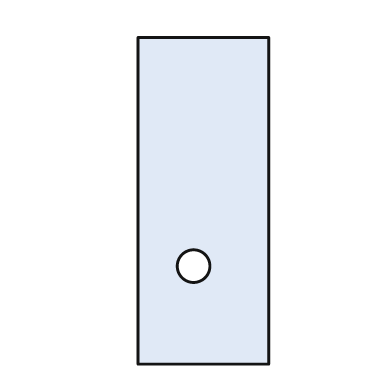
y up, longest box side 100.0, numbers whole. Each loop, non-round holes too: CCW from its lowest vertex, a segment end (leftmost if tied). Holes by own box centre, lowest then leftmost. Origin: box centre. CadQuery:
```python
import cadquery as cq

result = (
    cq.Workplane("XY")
    .moveTo(-20.0, -50.0)
    .lineTo(20.0, -50.0)
    .lineTo(20.0, 50.0)
    .lineTo(-20.0, 50.0)
    .close()
    .moveTo(-3.0, -20.0)
    .circle(5.0)
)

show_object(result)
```